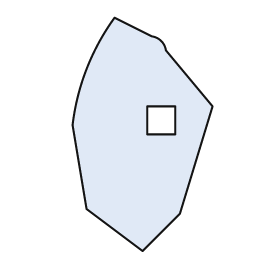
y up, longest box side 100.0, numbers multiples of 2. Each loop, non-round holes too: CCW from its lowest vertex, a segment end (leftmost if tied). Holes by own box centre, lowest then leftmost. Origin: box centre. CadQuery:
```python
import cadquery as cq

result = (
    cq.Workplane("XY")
    .moveTo(0.0, -50.0)
    .lineTo(16.0, -34.0)
    .lineTo(30.0, 12.0)
    .lineTo(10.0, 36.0)
    .threePointArc((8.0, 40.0), (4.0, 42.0))
    .lineTo(-12.0, 50.0)
    .threePointArc((-24.0, 28.0), (-30.0, 4.0))
    .lineTo(-24.0, -32.0)
    .close()
    .moveTo(2.0, 0.0)
    .lineTo(14.0, 0.0)
    .lineTo(14.0, 12.0)
    .lineTo(2.0, 12.0)
    .close()
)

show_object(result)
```